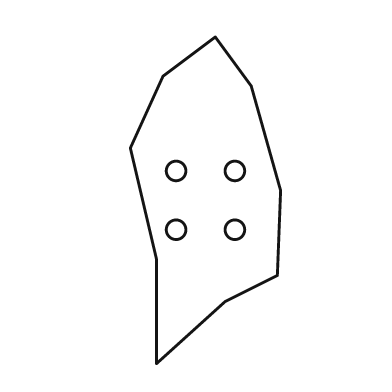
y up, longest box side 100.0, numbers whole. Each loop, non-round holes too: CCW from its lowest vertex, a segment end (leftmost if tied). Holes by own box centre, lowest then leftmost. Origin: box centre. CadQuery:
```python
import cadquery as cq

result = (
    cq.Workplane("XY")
    .moveTo(-15.0, -50.0)
    .lineTo(6.0, -31.0)
    .lineTo(22.0, -23.0)
    .lineTo(23.0, 3.0)
    .lineTo(14.0, 35.0)
    .lineTo(3.0, 50.0)
    .lineTo(-13.0, 38.0)
    .lineTo(-23.0, 16.0)
    .lineTo(-15.0, -18.0)
    .close()
    .moveTo(-9.0, -9.0)
    .circle(3.0)
    .moveTo(9.0, -9.0)
    .circle(3.0)
    .moveTo(-9.0, 9.0)
    .circle(3.0)
    .moveTo(9.0, 9.0)
    .circle(3.0)
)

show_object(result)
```